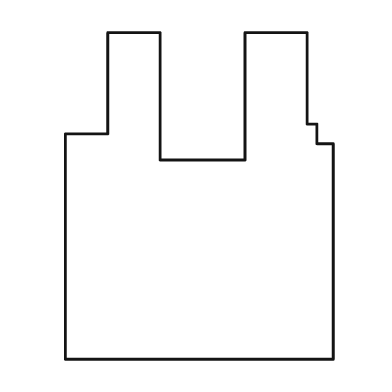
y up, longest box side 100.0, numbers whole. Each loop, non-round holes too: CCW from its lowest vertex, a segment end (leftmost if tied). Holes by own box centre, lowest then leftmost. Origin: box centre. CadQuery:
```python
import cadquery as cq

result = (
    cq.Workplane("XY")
    .moveTo(-41.0, -50.0)
    .lineTo(41.0, -50.0)
    .lineTo(41.0, 16.0)
    .lineTo(36.0, 16.0)
    .lineTo(36.0, 22.0)
    .lineTo(33.0, 22.0)
    .lineTo(33.0, 50.0)
    .lineTo(14.0, 50.0)
    .lineTo(14.0, 11.0)
    .lineTo(-12.0, 11.0)
    .lineTo(-12.0, 50.0)
    .lineTo(-28.0, 50.0)
    .lineTo(-28.0, 19.0)
    .lineTo(-41.0, 19.0)
    .close()
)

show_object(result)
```